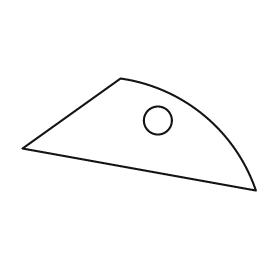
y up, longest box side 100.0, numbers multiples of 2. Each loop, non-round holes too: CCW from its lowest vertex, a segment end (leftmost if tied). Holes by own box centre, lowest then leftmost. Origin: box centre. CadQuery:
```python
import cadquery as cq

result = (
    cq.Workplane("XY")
    .moveTo(50.0, -24.0)
    .threePointArc((28.0, 8.0), (-8.0, 24.0))
    .lineTo(-50.0, -6.0)
    .close()
    .moveTo(8.0, 6.0)
    .circle(6.0)
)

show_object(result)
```